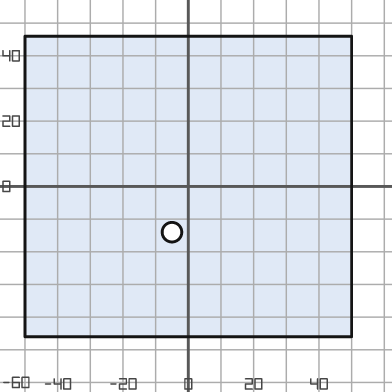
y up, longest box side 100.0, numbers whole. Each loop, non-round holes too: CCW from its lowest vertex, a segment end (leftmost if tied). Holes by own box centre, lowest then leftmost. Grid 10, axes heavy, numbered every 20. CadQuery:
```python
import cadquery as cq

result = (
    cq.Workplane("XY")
    .moveTo(-50.0, -46.0)
    .lineTo(50.0, -46.0)
    .lineTo(50.0, 46.0)
    .lineTo(-50.0, 46.0)
    .close()
    .moveTo(-5.0, -14.0)
    .circle(3.0)
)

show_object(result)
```